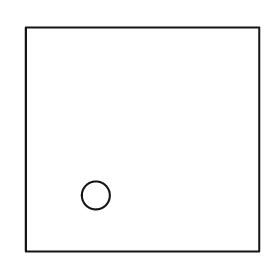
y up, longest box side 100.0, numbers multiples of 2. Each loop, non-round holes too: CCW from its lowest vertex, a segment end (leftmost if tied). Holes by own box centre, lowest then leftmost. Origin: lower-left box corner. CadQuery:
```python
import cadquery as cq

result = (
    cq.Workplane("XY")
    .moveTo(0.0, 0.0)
    .lineTo(100.0, 0.0)
    .lineTo(100.0, 96.0)
    .lineTo(0.0, 96.0)
    .close()
    .moveTo(30.0, 24.0)
    .circle(6.0)
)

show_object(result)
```